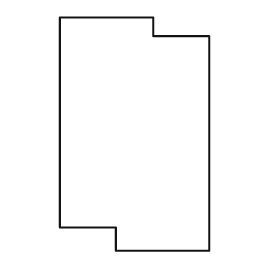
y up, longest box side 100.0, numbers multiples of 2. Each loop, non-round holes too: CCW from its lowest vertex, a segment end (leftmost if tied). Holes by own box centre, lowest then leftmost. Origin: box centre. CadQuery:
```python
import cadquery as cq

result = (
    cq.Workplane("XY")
    .moveTo(-8.0, -50.0)
    .lineTo(32.0, -50.0)
    .lineTo(32.0, 42.0)
    .lineTo(8.0, 42.0)
    .lineTo(8.0, 50.0)
    .lineTo(-32.0, 50.0)
    .lineTo(-32.0, -40.0)
    .lineTo(-8.0, -40.0)
    .close()
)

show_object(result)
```